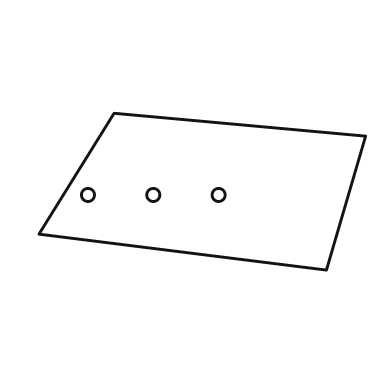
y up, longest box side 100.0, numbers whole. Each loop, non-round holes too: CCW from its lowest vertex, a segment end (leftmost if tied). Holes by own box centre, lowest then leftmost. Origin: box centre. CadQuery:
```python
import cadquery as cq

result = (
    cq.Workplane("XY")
    .moveTo(38.0, -24.0)
    .lineTo(50.0, 17.0)
    .lineTo(-27.0, 24.0)
    .lineTo(-50.0, -13.0)
    .close()
    .moveTo(-35.0, -1.0)
    .circle(2.0)
    .moveTo(-15.0, -1.0)
    .circle(2.0)
    .moveTo(5.0, -1.0)
    .circle(2.0)
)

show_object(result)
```